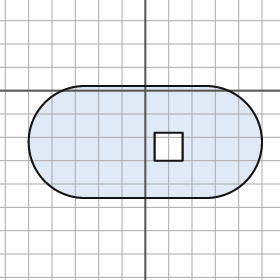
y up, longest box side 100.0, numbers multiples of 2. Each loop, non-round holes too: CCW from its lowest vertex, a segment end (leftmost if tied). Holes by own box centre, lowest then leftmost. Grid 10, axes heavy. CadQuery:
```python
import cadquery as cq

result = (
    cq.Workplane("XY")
    .moveTo(-26.0, -46.0)
    .lineTo(26.0, -46.0)
    .threePointArc((50.0, -22.0), (26.0, 2.0))
    .lineTo(-26.0, 2.0)
    .threePointArc((-50.0, -22.0), (-26.0, -46.0))
    .close()
    .moveTo(4.0, -30.0)
    .lineTo(16.0, -30.0)
    .lineTo(16.0, -18.0)
    .lineTo(4.0, -18.0)
    .close()
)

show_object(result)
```